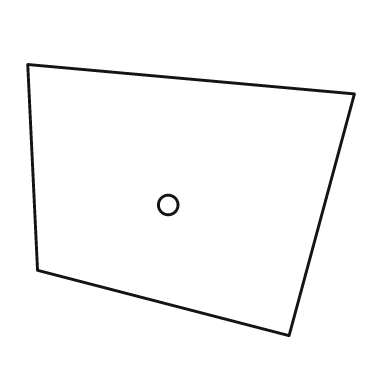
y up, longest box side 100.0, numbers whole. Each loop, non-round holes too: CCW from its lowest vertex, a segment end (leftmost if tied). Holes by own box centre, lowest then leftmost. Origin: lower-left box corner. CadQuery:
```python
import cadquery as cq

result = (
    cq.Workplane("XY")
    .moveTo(80.0, 0.0)
    .lineTo(100.0, 74.0)
    .lineTo(0.0, 83.0)
    .lineTo(3.0, 20.0)
    .close()
    .moveTo(43.0, 40.0)
    .circle(3.0)
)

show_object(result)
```